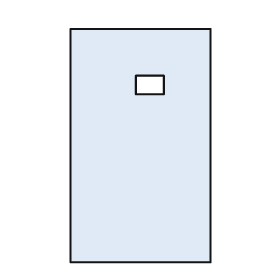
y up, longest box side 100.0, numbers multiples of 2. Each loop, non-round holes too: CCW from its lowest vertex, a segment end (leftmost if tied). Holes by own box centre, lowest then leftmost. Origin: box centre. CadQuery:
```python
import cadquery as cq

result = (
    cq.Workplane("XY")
    .moveTo(-30.0, -50.0)
    .lineTo(30.0, -50.0)
    .lineTo(30.0, 50.0)
    .lineTo(-30.0, 50.0)
    .close()
    .moveTo(-2.0, 22.0)
    .lineTo(10.0, 22.0)
    .lineTo(10.0, 30.0)
    .lineTo(-2.0, 30.0)
    .close()
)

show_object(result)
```